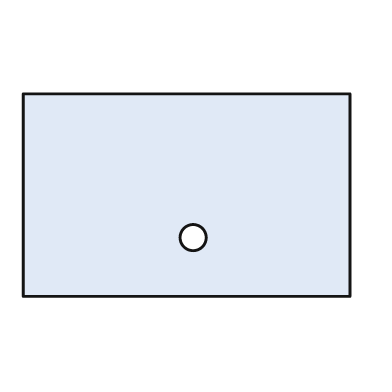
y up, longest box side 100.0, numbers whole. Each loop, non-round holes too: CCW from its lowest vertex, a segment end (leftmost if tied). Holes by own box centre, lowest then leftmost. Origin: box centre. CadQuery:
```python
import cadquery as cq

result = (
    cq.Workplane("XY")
    .moveTo(-50.0, -31.0)
    .lineTo(50.0, -31.0)
    .lineTo(50.0, 31.0)
    .lineTo(-50.0, 31.0)
    .close()
    .moveTo(2.0, -13.0)
    .circle(4.0)
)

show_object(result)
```